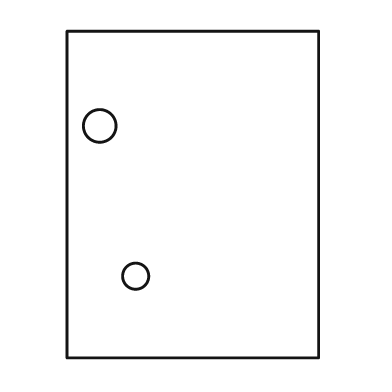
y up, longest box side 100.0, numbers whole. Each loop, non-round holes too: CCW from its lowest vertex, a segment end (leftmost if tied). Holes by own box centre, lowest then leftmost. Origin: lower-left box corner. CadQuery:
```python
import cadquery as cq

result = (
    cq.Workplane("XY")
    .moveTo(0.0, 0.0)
    .lineTo(77.0, 0.0)
    .lineTo(77.0, 100.0)
    .lineTo(0.0, 100.0)
    .close()
    .moveTo(21.0, 25.0)
    .circle(4.0)
    .moveTo(10.0, 71.0)
    .circle(5.0)
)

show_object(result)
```